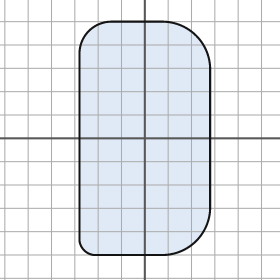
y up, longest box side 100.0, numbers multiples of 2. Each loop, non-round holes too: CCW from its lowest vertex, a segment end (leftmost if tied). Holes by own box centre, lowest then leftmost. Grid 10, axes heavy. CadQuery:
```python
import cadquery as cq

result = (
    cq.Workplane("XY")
    .moveTo(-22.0, -50.0)
    .lineTo(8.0, -50.0)
    .threePointArc((22.0, -44.0), (28.0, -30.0))
    .lineTo(28.0, 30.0)
    .threePointArc((22.0, 44.0), (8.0, 50.0))
    .lineTo(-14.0, 50.0)
    .threePointArc((-24.0, 46.0), (-28.0, 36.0))
    .lineTo(-28.0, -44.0)
    .threePointArc((-26.0, -48.0), (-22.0, -50.0))
    .close()
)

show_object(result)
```